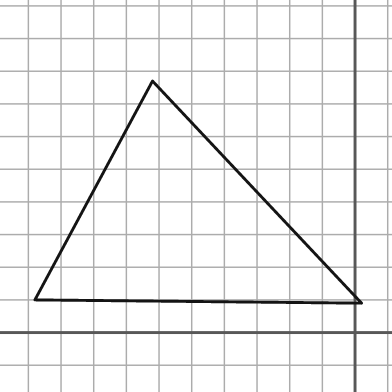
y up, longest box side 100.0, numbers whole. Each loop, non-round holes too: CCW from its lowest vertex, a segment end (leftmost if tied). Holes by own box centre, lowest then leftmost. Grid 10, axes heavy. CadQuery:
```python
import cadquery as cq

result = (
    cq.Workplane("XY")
    .moveTo(2.0, 9.0)
    .lineTo(-62.0, 77.0)
    .lineTo(-98.0, 10.0)
    .close()
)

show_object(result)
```